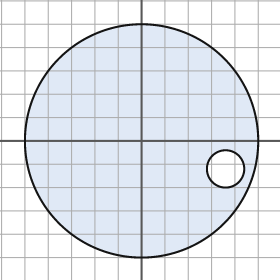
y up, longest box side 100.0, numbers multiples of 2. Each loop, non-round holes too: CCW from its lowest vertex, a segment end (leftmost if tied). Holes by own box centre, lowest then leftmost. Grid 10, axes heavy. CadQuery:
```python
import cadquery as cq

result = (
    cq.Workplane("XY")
    .moveTo(0.0, 0.0)
    .circle(50.0)
    .moveTo(36.0, -12.0)
    .circle(8.0)
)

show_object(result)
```